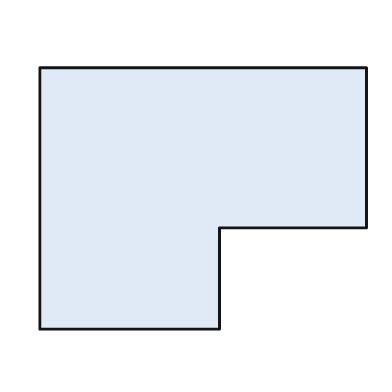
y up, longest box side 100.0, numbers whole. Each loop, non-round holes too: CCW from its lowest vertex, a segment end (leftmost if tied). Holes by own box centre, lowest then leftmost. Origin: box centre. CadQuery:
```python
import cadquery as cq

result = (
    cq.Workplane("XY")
    .moveTo(-50.0, -40.0)
    .lineTo(5.0, -40.0)
    .lineTo(5.0, -9.0)
    .lineTo(50.0, -9.0)
    .lineTo(50.0, 40.0)
    .lineTo(-50.0, 40.0)
    .close()
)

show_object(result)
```